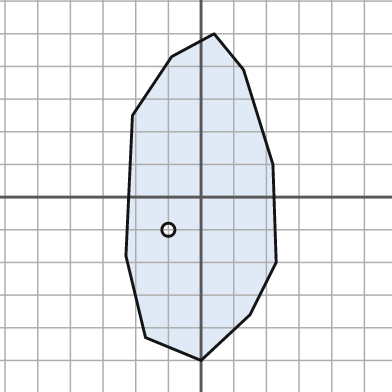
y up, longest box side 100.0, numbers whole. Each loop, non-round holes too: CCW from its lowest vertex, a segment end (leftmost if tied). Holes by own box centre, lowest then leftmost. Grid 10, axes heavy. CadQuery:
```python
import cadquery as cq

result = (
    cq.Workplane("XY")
    .moveTo(0.0, -50.0)
    .lineTo(15.0, -36.0)
    .lineTo(23.0, -20.0)
    .lineTo(22.0, 10.0)
    .lineTo(13.0, 39.0)
    .lineTo(4.0, 50.0)
    .lineTo(-9.0, 43.0)
    .lineTo(-21.0, 25.0)
    .lineTo(-23.0, -18.0)
    .lineTo(-17.0, -43.0)
    .close()
    .moveTo(-10.0, -10.0)
    .circle(2.0)
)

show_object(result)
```